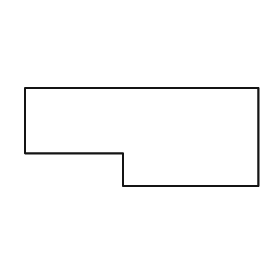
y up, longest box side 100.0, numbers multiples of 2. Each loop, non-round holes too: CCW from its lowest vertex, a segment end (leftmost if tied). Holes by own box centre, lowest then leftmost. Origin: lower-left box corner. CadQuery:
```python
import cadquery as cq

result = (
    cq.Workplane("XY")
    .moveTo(42.0, 0.0)
    .lineTo(100.0, 0.0)
    .lineTo(100.0, 42.0)
    .lineTo(0.0, 42.0)
    .lineTo(0.0, 14.0)
    .lineTo(42.0, 14.0)
    .close()
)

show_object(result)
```